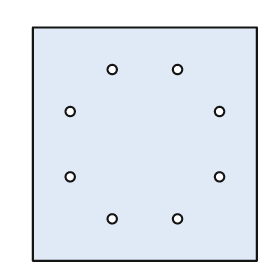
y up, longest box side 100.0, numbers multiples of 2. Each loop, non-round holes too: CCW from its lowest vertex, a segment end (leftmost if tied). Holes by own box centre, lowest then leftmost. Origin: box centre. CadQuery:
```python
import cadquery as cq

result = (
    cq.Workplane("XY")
    .moveTo(-48.0, -50.0)
    .lineTo(48.0, -50.0)
    .lineTo(48.0, 50.0)
    .lineTo(-48.0, 50.0)
    .close()
    .moveTo(-14.0, -32.0)
    .circle(2.0)
    .moveTo(14.0, -32.0)
    .circle(2.0)
    .moveTo(-32.0, -14.0)
    .circle(2.0)
    .moveTo(32.0, -14.0)
    .circle(2.0)
    .moveTo(-32.0, 14.0)
    .circle(2.0)
    .moveTo(32.0, 14.0)
    .circle(2.0)
    .moveTo(-14.0, 32.0)
    .circle(2.0)
    .moveTo(14.0, 32.0)
    .circle(2.0)
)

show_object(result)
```